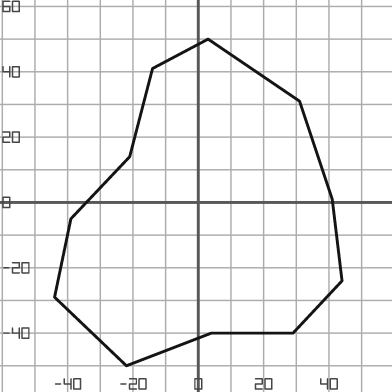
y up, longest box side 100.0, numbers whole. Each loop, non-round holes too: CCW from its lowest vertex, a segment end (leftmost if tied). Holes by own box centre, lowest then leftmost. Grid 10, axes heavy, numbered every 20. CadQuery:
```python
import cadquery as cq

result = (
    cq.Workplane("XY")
    .moveTo(-22.0, -50.0)
    .lineTo(4.0, -40.0)
    .lineTo(29.0, -40.0)
    .lineTo(44.0, -24.0)
    .lineTo(41.0, 1.0)
    .lineTo(31.0, 31.0)
    .lineTo(3.0, 50.0)
    .lineTo(-14.0, 41.0)
    .lineTo(-21.0, 14.0)
    .lineTo(-39.0, -5.0)
    .lineTo(-44.0, -29.0)
    .close()
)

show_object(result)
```